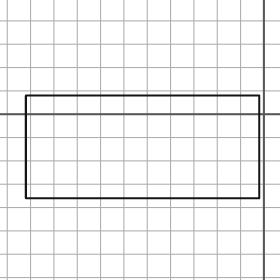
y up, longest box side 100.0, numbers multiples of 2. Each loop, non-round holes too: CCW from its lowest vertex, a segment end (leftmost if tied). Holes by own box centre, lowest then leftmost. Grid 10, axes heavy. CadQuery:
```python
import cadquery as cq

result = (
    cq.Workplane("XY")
    .moveTo(-102.0, -36.0)
    .lineTo(-2.0, -36.0)
    .lineTo(-2.0, 8.0)
    .lineTo(-102.0, 8.0)
    .close()
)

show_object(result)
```